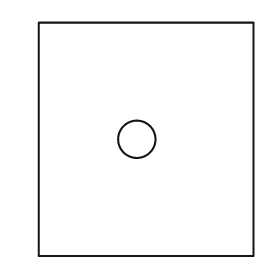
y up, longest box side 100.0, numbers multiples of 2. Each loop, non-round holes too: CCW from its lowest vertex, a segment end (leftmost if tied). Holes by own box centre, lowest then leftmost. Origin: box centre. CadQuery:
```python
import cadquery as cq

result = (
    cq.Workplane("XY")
    .moveTo(-46.0, -50.0)
    .lineTo(46.0, -50.0)
    .lineTo(46.0, 50.0)
    .lineTo(-46.0, 50.0)
    .close()
    .moveTo(-4.0, 0.0)
    .circle(8.0)
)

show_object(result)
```